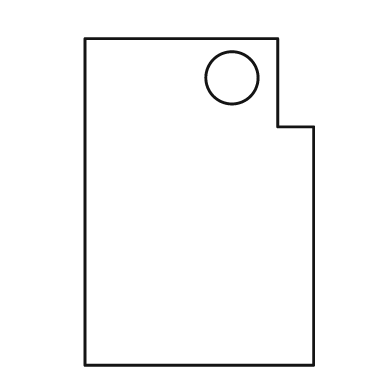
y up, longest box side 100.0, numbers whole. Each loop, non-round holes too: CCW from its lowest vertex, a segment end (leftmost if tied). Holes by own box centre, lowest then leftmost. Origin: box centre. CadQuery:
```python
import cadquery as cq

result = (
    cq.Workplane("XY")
    .moveTo(-35.0, -50.0)
    .lineTo(35.0, -50.0)
    .lineTo(35.0, 23.0)
    .lineTo(24.0, 23.0)
    .lineTo(24.0, 50.0)
    .lineTo(-35.0, 50.0)
    .close()
    .moveTo(10.0, 38.0)
    .circle(8.0)
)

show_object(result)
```